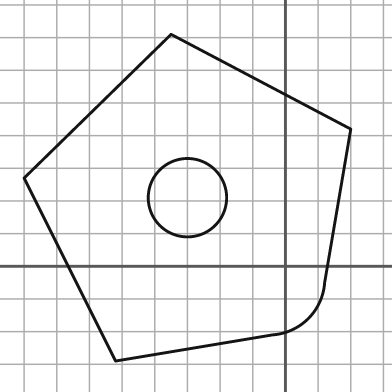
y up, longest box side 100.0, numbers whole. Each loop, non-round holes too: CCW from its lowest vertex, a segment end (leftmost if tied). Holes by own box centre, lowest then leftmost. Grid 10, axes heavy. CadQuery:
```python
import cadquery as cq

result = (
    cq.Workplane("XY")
    .moveTo(-52.0, -29.0)
    .lineTo(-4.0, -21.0)
    .threePointArc((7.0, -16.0), (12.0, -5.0))
    .lineTo(20.0, 42.0)
    .lineTo(-35.0, 71.0)
    .lineTo(-80.0, 27.0)
    .close()
    .moveTo(-30.0, 21.0)
    .circle(12.0)
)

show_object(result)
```